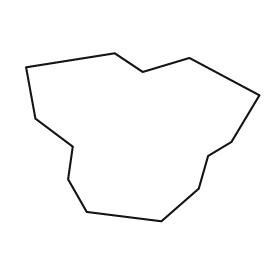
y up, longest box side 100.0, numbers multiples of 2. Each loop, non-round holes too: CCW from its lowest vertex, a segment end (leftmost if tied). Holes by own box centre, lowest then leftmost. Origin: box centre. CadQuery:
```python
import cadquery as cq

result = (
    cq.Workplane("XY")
    .moveTo(8.0, -36.0)
    .lineTo(24.0, -22.0)
    .lineTo(28.0, -8.0)
    .lineTo(38.0, -2.0)
    .lineTo(50.0, 18.0)
    .lineTo(20.0, 34.0)
    .lineTo(0.0, 28.0)
    .lineTo(-12.0, 36.0)
    .lineTo(-50.0, 30.0)
    .lineTo(-46.0, 8.0)
    .lineTo(-30.0, -4.0)
    .lineTo(-32.0, -18.0)
    .lineTo(-24.0, -32.0)
    .close()
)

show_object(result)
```